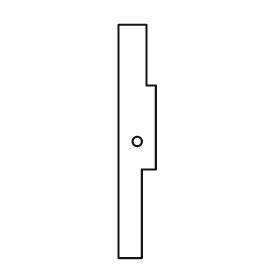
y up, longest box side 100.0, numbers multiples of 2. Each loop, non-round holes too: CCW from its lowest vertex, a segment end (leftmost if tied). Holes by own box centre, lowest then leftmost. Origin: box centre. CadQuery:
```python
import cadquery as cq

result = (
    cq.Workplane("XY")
    .moveTo(-8.0, -50.0)
    .lineTo(2.0, -50.0)
    .lineTo(2.0, -12.0)
    .lineTo(8.0, -12.0)
    .lineTo(8.0, 24.0)
    .lineTo(4.0, 24.0)
    .lineTo(4.0, 50.0)
    .lineTo(-8.0, 50.0)
    .close()
    .moveTo(0.0, 0.0)
    .circle(2.0)
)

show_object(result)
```